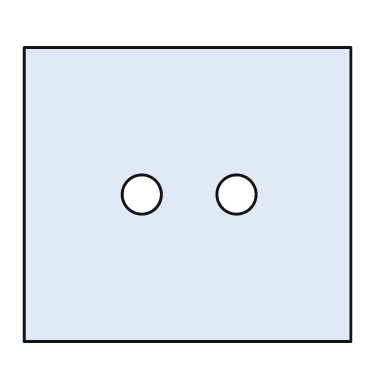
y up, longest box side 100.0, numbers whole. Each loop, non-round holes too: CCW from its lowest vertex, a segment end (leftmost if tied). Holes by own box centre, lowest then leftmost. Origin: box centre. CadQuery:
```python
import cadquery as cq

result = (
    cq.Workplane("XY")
    .moveTo(-50.0, -45.0)
    .lineTo(50.0, -45.0)
    .lineTo(50.0, 45.0)
    .lineTo(-50.0, 45.0)
    .close()
    .moveTo(-14.0, 0.0)
    .circle(6.0)
    .moveTo(15.0, 0.0)
    .circle(6.0)
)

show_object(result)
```